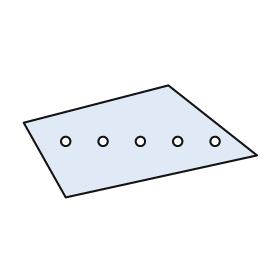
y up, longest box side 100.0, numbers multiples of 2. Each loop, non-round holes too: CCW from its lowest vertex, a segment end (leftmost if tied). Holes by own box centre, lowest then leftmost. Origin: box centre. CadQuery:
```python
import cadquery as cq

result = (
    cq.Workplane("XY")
    .moveTo(-32.0, -24.0)
    .lineTo(50.0, -6.0)
    .lineTo(12.0, 24.0)
    .lineTo(-50.0, 8.0)
    .close()
    .moveTo(-32.0, 0.0)
    .circle(2.0)
    .moveTo(-16.0, 0.0)
    .circle(2.0)
    .moveTo(0.0, 0.0)
    .circle(2.0)
    .moveTo(16.0, 0.0)
    .circle(2.0)
    .moveTo(32.0, 0.0)
    .circle(2.0)
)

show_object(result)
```